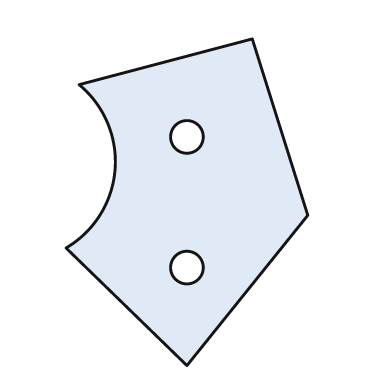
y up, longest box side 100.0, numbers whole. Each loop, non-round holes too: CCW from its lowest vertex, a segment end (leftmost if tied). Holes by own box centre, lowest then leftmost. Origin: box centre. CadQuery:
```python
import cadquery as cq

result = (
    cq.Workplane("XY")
    .moveTo(0.0, -50.0)
    .lineTo(37.0, -4.0)
    .lineTo(20.0, 50.0)
    .lineTo(-33.0, 36.0)
    .threePointArc((-22.0, 10.0), (-37.0, -14.0))
    .close()
    .moveTo(0.0, -20.0)
    .circle(5.0)
    .moveTo(0.0, 20.0)
    .circle(5.0)
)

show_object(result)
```